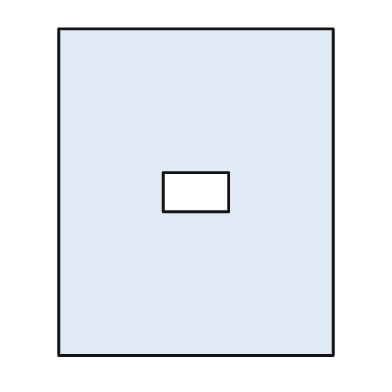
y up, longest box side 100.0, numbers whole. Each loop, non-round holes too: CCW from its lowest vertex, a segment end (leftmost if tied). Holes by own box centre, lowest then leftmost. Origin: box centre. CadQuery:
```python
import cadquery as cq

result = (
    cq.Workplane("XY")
    .moveTo(-42.0, -50.0)
    .lineTo(42.0, -50.0)
    .lineTo(42.0, 50.0)
    .lineTo(-42.0, 50.0)
    .close()
    .moveTo(-10.0, -6.0)
    .lineTo(10.0, -6.0)
    .lineTo(10.0, 6.0)
    .lineTo(-10.0, 6.0)
    .close()
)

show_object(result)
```